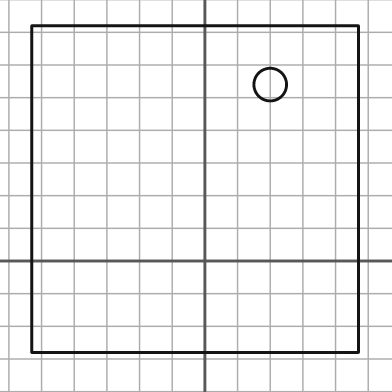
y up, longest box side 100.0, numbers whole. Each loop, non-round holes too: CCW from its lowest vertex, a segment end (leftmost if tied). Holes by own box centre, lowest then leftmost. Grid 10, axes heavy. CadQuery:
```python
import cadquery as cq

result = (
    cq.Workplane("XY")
    .moveTo(-53.0, -28.0)
    .lineTo(47.0, -28.0)
    .lineTo(47.0, 72.0)
    .lineTo(-53.0, 72.0)
    .close()
    .moveTo(20.0, 54.0)
    .circle(5.0)
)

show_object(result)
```